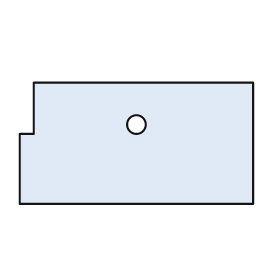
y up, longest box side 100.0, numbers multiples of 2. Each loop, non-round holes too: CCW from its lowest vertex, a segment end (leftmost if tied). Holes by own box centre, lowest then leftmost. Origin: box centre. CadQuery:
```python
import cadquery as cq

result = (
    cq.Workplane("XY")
    .moveTo(-50.0, -26.0)
    .lineTo(50.0, -26.0)
    .lineTo(50.0, 26.0)
    .lineTo(-44.0, 26.0)
    .lineTo(-44.0, 4.0)
    .lineTo(-50.0, 4.0)
    .close()
    .moveTo(0.0, 8.0)
    .circle(4.0)
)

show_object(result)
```